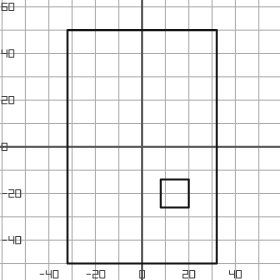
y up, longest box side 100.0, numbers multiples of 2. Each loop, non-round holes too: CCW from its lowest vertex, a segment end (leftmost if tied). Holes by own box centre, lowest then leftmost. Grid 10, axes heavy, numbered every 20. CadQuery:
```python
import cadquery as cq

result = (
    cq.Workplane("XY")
    .moveTo(-32.0, -50.0)
    .lineTo(32.0, -50.0)
    .lineTo(32.0, 50.0)
    .lineTo(-32.0, 50.0)
    .close()
    .moveTo(8.0, -26.0)
    .lineTo(20.0, -26.0)
    .lineTo(20.0, -14.0)
    .lineTo(8.0, -14.0)
    .close()
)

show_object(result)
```